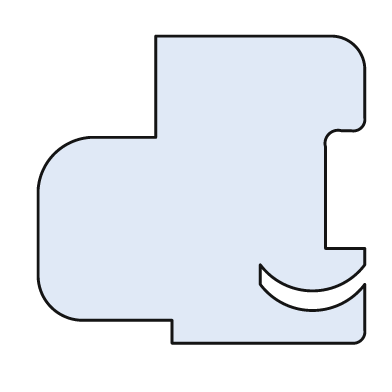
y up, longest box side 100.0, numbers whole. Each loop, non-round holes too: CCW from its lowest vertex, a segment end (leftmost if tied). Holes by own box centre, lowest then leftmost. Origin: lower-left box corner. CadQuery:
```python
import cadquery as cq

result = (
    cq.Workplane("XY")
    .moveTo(41.0, 0.0)
    .lineTo(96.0, 0.0)
    .threePointArc((99.0, 1.0), (100.0, 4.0))
    .lineTo(100.0, 18.0)
    .threePointArc((84.0, 10.0), (68.0, 18.0))
    .lineTo(68.0, 24.0)
    .threePointArc((84.0, 16.0), (100.0, 24.0))
    .lineTo(100.0, 29.0)
    .lineTo(88.0, 29.0)
    .lineTo(88.0, 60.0)
    .threePointArc((89.0, 64.0), (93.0, 65.0))
    .lineTo(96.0, 65.0)
    .threePointArc((99.0, 66.0), (100.0, 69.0))
    .lineTo(100.0, 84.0)
    .threePointArc((97.0, 91.0), (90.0, 94.0))
    .lineTo(36.0, 94.0)
    .lineTo(36.0, 63.0)
    .lineTo(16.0, 63.0)
    .threePointArc((5.0, 58.0), (0.0, 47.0))
    .lineTo(0.0, 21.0)
    .threePointArc((4.0, 11.0), (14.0, 7.0))
    .lineTo(41.0, 7.0)
    .close()
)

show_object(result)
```